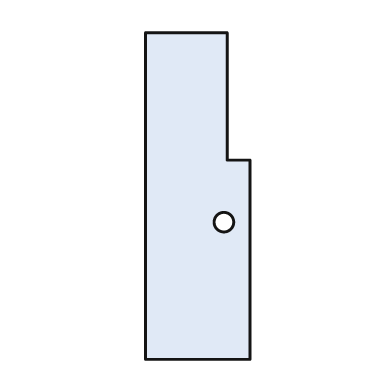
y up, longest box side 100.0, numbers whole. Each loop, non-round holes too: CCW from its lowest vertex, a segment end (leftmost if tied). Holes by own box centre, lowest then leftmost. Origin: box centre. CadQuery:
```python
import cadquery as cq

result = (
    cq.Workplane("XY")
    .moveTo(-16.0, -50.0)
    .lineTo(16.0, -50.0)
    .lineTo(16.0, 11.0)
    .lineTo(9.0, 11.0)
    .lineTo(9.0, 50.0)
    .lineTo(-16.0, 50.0)
    .close()
    .moveTo(8.0, -8.0)
    .circle(3.0)
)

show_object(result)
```